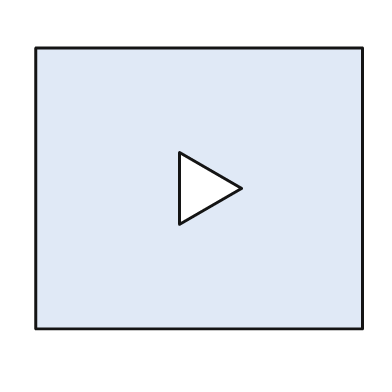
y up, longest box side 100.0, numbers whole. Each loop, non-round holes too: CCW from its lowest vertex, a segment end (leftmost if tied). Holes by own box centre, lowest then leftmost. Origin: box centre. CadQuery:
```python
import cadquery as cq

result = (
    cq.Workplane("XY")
    .moveTo(-50.0, -43.0)
    .lineTo(50.0, -43.0)
    .lineTo(50.0, 43.0)
    .lineTo(-50.0, 43.0)
    .close()
    .moveTo(-6.0, -11.0)
    .lineTo(13.0, 0.0)
    .lineTo(-6.0, 11.0)
    .close()
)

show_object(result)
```